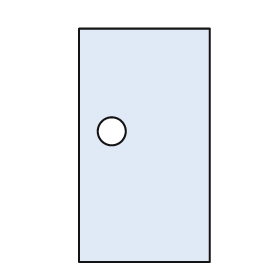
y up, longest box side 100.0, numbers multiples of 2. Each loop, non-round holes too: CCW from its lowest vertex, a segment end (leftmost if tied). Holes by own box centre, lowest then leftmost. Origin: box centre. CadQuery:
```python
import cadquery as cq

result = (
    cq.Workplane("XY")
    .moveTo(-28.0, -50.0)
    .lineTo(28.0, -50.0)
    .lineTo(28.0, 50.0)
    .lineTo(-28.0, 50.0)
    .close()
    .moveTo(-14.0, 6.0)
    .circle(6.0)
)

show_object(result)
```